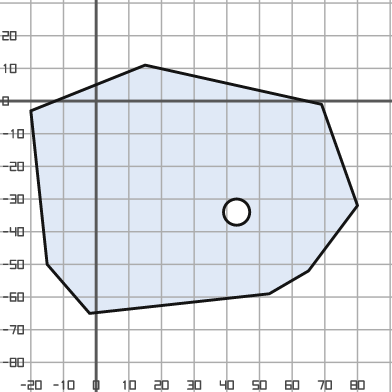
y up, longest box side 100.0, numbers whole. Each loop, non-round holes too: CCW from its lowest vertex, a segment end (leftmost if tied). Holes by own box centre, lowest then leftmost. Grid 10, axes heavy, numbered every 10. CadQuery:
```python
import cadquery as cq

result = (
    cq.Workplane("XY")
    .moveTo(-2.0, -65.0)
    .lineTo(53.0, -59.0)
    .lineTo(65.0, -52.0)
    .lineTo(80.0, -32.0)
    .lineTo(69.0, -1.0)
    .lineTo(15.0, 11.0)
    .lineTo(-20.0, -3.0)
    .lineTo(-15.0, -50.0)
    .close()
    .moveTo(43.0, -34.0)
    .circle(4.0)
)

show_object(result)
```